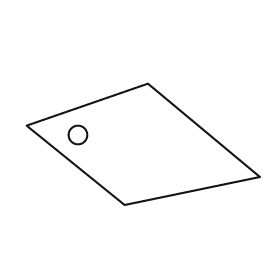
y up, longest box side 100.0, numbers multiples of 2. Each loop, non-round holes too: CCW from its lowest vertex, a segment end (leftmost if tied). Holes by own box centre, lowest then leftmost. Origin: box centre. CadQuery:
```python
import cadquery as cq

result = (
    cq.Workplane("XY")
    .moveTo(-8.0, -26.0)
    .lineTo(50.0, -14.0)
    .lineTo(2.0, 26.0)
    .lineTo(-50.0, 8.0)
    .close()
    .moveTo(-28.0, 4.0)
    .circle(4.0)
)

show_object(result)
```